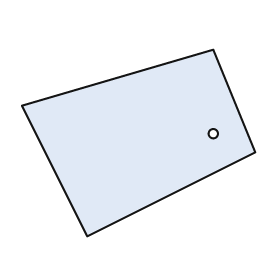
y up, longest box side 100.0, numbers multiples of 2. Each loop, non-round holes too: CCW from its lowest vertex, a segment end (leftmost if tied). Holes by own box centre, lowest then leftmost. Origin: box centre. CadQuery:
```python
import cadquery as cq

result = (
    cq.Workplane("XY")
    .moveTo(-22.0, -40.0)
    .lineTo(50.0, -4.0)
    .lineTo(32.0, 40.0)
    .lineTo(-50.0, 16.0)
    .close()
    .moveTo(32.0, 4.0)
    .circle(2.0)
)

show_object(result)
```